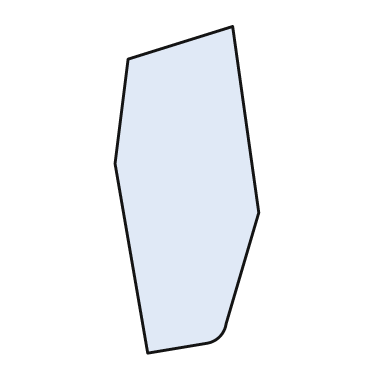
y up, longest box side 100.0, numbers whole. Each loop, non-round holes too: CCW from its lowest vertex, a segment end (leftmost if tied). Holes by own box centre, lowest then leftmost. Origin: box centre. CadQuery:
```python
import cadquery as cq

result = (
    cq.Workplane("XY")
    .moveTo(-12.0, -50.0)
    .lineTo(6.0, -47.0)
    .threePointArc((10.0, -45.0), (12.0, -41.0))
    .lineTo(22.0, -7.0)
    .lineTo(14.0, 50.0)
    .lineTo(-18.0, 40.0)
    .lineTo(-22.0, 8.0)
    .close()
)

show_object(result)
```